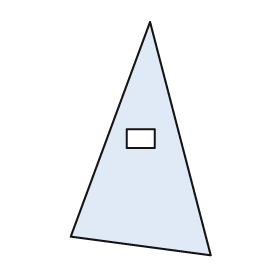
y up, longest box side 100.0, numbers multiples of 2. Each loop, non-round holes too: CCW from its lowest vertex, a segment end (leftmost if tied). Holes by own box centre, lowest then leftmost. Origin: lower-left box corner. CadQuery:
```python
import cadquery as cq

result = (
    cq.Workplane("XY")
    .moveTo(60.0, 0.0)
    .lineTo(34.0, 100.0)
    .lineTo(0.0, 8.0)
    .close()
    .moveTo(24.0, 46.0)
    .lineTo(36.0, 46.0)
    .lineTo(36.0, 54.0)
    .lineTo(24.0, 54.0)
    .close()
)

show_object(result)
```